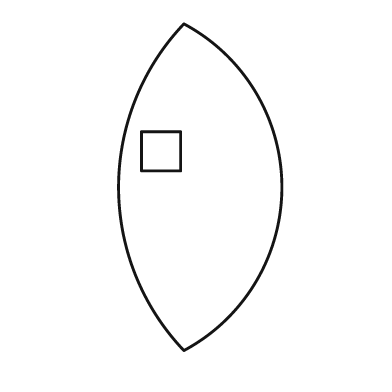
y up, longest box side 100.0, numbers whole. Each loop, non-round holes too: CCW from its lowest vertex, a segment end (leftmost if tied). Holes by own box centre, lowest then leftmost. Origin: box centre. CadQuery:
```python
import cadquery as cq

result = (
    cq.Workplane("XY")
    .moveTo(-5.0, -50.0)
    .threePointArc((25.0, 0.0), (-5.0, 50.0))
    .threePointArc((-25.0, 0.0), (-5.0, -50.0))
    .close()
    .moveTo(-18.0, 5.0)
    .lineTo(-6.0, 5.0)
    .lineTo(-6.0, 17.0)
    .lineTo(-18.0, 17.0)
    .close()
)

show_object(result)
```